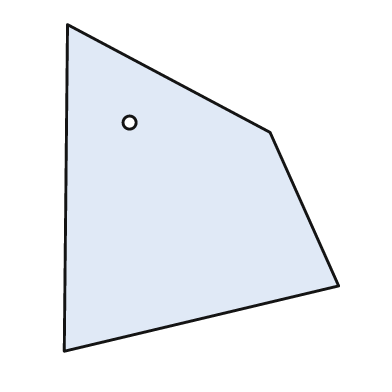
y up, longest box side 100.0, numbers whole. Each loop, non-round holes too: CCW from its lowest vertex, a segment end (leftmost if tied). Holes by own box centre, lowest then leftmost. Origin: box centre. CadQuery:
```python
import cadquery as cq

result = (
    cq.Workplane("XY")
    .moveTo(-42.0, -50.0)
    .lineTo(42.0, -30.0)
    .lineTo(21.0, 17.0)
    .lineTo(-41.0, 50.0)
    .close()
    .moveTo(-22.0, 20.0)
    .circle(2.0)
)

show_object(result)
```